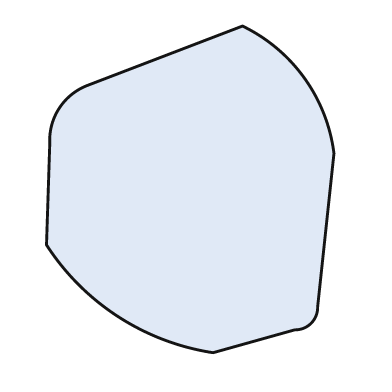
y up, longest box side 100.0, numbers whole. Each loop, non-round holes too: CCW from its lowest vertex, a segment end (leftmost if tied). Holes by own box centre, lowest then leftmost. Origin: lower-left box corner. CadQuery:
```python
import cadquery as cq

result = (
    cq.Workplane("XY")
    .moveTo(51.0, 0.0)
    .lineTo(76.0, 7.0)
    .threePointArc((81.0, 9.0), (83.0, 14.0))
    .lineTo(88.0, 61.0)
    .threePointArc((79.0, 84.0), (60.0, 100.0))
    .lineTo(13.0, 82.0)
    .threePointArc((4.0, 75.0), (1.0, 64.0))
    .lineTo(0.0, 33.0)
    .threePointArc((22.0, 11.0), (51.0, 0.0))
    .close()
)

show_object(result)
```